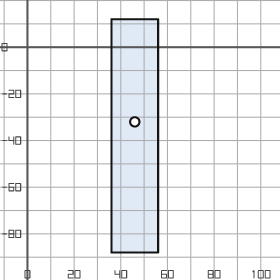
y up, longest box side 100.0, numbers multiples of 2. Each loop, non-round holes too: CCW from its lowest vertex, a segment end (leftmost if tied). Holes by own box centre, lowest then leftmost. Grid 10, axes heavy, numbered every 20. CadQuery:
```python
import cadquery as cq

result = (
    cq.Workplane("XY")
    .moveTo(36.0, -88.0)
    .lineTo(56.0, -88.0)
    .lineTo(56.0, 12.0)
    .lineTo(36.0, 12.0)
    .close()
    .moveTo(46.0, -32.0)
    .circle(2.0)
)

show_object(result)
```